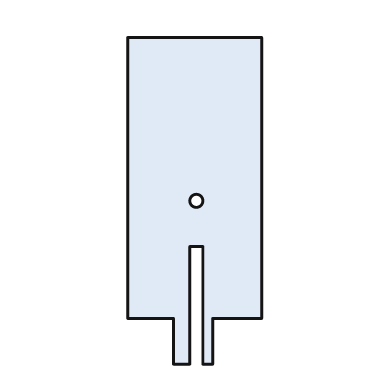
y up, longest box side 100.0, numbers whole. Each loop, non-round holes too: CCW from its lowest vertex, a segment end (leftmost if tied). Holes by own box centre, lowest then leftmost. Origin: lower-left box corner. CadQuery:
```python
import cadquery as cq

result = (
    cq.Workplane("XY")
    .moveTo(14.0, 0.0)
    .lineTo(19.0, 0.0)
    .lineTo(19.0, 36.0)
    .lineTo(23.0, 36.0)
    .lineTo(23.0, 0.0)
    .lineTo(26.0, 0.0)
    .lineTo(26.0, 14.0)
    .lineTo(41.0, 14.0)
    .lineTo(41.0, 100.0)
    .lineTo(0.0, 100.0)
    .lineTo(0.0, 14.0)
    .lineTo(14.0, 14.0)
    .close()
    .moveTo(21.0, 50.0)
    .circle(2.0)
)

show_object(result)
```